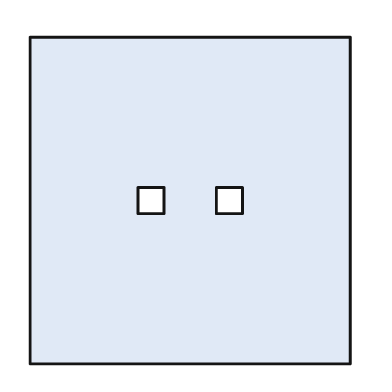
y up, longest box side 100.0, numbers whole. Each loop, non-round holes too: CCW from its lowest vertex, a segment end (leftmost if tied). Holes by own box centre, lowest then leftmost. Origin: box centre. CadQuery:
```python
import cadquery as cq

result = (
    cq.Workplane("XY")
    .moveTo(-49.0, -50.0)
    .lineTo(49.0, -50.0)
    .lineTo(49.0, 50.0)
    .lineTo(-49.0, 50.0)
    .close()
    .moveTo(-16.0, -4.0)
    .lineTo(-8.0, -4.0)
    .lineTo(-8.0, 4.0)
    .lineTo(-16.0, 4.0)
    .close()
    .moveTo(8.0, -4.0)
    .lineTo(16.0, -4.0)
    .lineTo(16.0, 4.0)
    .lineTo(8.0, 4.0)
    .close()
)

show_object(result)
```